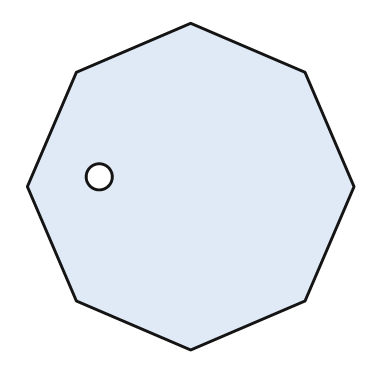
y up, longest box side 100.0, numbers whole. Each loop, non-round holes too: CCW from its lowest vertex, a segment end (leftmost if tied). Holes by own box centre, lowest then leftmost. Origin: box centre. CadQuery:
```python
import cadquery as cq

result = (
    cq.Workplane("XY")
    .moveTo(0.0, -50.0)
    .lineTo(35.0, -35.0)
    .lineTo(50.0, 0.0)
    .lineTo(35.0, 35.0)
    .lineTo(0.0, 50.0)
    .lineTo(-35.0, 35.0)
    .lineTo(-50.0, 0.0)
    .lineTo(-35.0, -35.0)
    .close()
    .moveTo(-28.0, 3.0)
    .circle(4.0)
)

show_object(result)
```